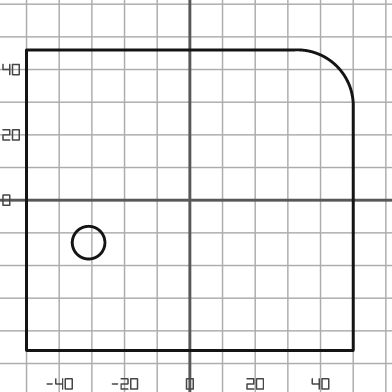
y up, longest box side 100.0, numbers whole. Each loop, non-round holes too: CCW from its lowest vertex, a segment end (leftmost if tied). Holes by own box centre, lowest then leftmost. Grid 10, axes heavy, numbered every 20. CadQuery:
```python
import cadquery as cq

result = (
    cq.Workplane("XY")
    .moveTo(-50.0, -46.0)
    .lineTo(50.0, -46.0)
    .lineTo(50.0, 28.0)
    .threePointArc((45.0, 41.0), (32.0, 46.0))
    .lineTo(-50.0, 46.0)
    .close()
    .moveTo(-31.0, -13.0)
    .circle(5.0)
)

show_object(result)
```